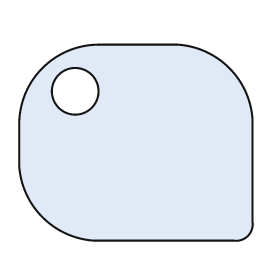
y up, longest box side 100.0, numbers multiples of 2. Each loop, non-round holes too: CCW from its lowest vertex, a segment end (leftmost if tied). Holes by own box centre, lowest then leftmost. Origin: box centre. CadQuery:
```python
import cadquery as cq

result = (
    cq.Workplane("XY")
    .moveTo(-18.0, -42.0)
    .lineTo(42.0, -42.0)
    .threePointArc((48.0, -40.0), (50.0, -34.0))
    .lineTo(50.0, 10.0)
    .threePointArc((40.0, 32.0), (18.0, 42.0))
    .lineTo(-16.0, 42.0)
    .threePointArc((-40.0, 32.0), (-50.0, 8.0))
    .lineTo(-50.0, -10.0)
    .threePointArc((-40.0, -32.0), (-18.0, -42.0))
    .close()
    .moveTo(-26.0, 22.0)
    .circle(10.0)
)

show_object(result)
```